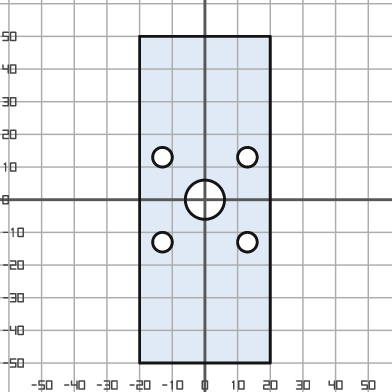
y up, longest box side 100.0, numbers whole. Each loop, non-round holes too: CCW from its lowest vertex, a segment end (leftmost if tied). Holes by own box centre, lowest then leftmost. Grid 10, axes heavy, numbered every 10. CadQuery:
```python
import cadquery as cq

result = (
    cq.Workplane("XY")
    .moveTo(-20.0, -50.0)
    .lineTo(20.0, -50.0)
    .lineTo(20.0, 50.0)
    .lineTo(-20.0, 50.0)
    .close()
    .moveTo(-13.0, -13.0)
    .circle(3.0)
    .moveTo(13.0, -13.0)
    .circle(3.0)
    .moveTo(0.0, 0.0)
    .circle(6.0)
    .moveTo(-13.0, 13.0)
    .circle(3.0)
    .moveTo(13.0, 13.0)
    .circle(3.0)
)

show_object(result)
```